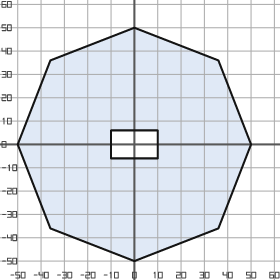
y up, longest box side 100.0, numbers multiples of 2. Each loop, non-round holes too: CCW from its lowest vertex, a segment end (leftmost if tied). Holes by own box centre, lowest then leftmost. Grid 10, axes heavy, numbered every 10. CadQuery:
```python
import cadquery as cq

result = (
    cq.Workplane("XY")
    .moveTo(0.0, -50.0)
    .lineTo(36.0, -36.0)
    .lineTo(50.0, 0.0)
    .lineTo(36.0, 36.0)
    .lineTo(0.0, 50.0)
    .lineTo(-36.0, 36.0)
    .lineTo(-50.0, 0.0)
    .lineTo(-36.0, -36.0)
    .close()
    .moveTo(-10.0, -6.0)
    .lineTo(10.0, -6.0)
    .lineTo(10.0, 6.0)
    .lineTo(-10.0, 6.0)
    .close()
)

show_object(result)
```